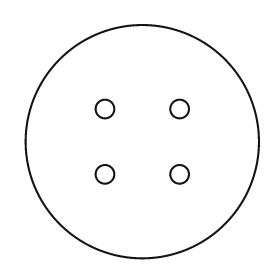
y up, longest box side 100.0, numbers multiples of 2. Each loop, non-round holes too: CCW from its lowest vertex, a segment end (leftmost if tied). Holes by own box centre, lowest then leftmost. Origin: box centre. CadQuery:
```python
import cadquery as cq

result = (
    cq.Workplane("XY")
    .moveTo(0.0, 0.0)
    .circle(50.0)
    .moveTo(-16.0, -14.0)
    .circle(4.0)
    .moveTo(16.0, -14.0)
    .circle(4.0)
    .moveTo(-16.0, 14.0)
    .circle(4.0)
    .moveTo(16.0, 14.0)
    .circle(4.0)
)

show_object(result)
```